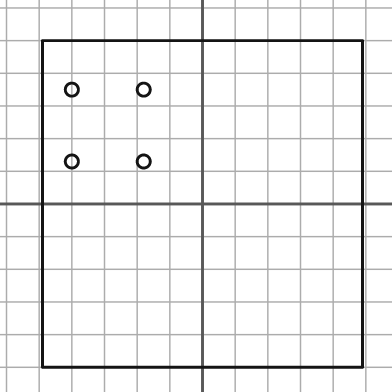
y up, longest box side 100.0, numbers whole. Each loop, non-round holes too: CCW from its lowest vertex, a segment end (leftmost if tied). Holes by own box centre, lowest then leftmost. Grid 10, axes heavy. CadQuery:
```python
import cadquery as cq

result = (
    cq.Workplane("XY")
    .moveTo(-49.0, -50.0)
    .lineTo(49.0, -50.0)
    .lineTo(49.0, 50.0)
    .lineTo(-49.0, 50.0)
    .close()
    .moveTo(-40.0, 13.0)
    .circle(2.0)
    .moveTo(-18.0, 13.0)
    .circle(2.0)
    .moveTo(-40.0, 35.0)
    .circle(2.0)
    .moveTo(-18.0, 35.0)
    .circle(2.0)
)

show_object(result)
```